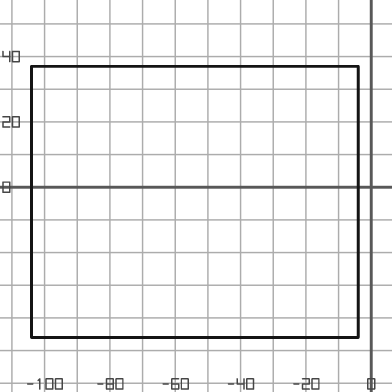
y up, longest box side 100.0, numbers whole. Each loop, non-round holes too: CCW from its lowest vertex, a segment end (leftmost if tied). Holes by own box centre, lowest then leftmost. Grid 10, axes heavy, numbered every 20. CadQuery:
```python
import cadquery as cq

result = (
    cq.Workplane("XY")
    .moveTo(-104.0, -46.0)
    .lineTo(-4.0, -46.0)
    .lineTo(-4.0, 37.0)
    .lineTo(-104.0, 37.0)
    .close()
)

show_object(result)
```